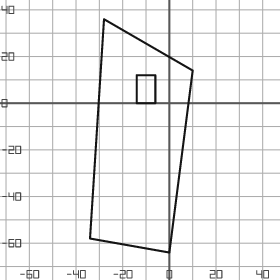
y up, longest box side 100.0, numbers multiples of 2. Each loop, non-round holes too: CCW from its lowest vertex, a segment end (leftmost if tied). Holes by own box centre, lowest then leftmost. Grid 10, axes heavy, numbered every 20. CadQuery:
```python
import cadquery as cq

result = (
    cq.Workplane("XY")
    .moveTo(0.0, -64.0)
    .lineTo(10.0, 14.0)
    .lineTo(-28.0, 36.0)
    .lineTo(-34.0, -58.0)
    .close()
    .moveTo(-14.0, 0.0)
    .lineTo(-6.0, 0.0)
    .lineTo(-6.0, 12.0)
    .lineTo(-14.0, 12.0)
    .close()
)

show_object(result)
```